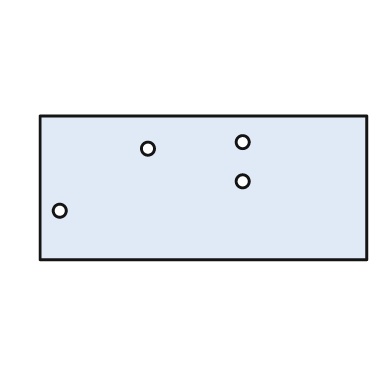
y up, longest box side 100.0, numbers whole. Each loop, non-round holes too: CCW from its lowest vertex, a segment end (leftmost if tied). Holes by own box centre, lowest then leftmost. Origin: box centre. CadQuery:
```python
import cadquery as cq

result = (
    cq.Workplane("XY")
    .moveTo(-50.0, -22.0)
    .lineTo(50.0, -22.0)
    .lineTo(50.0, 22.0)
    .lineTo(-50.0, 22.0)
    .close()
    .moveTo(-44.0, -7.0)
    .circle(2.0)
    .moveTo(12.0, 2.0)
    .circle(2.0)
    .moveTo(-17.0, 12.0)
    .circle(2.0)
    .moveTo(12.0, 14.0)
    .circle(2.0)
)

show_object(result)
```